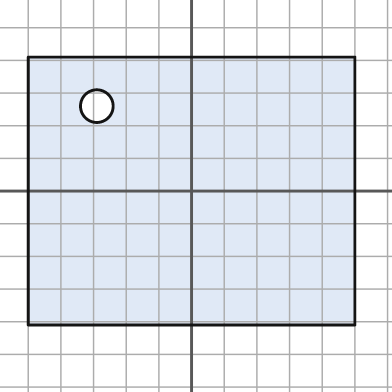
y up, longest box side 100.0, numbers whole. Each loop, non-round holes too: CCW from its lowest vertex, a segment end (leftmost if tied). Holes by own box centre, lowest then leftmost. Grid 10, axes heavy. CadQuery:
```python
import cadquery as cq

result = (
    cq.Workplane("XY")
    .moveTo(-50.0, -41.0)
    .lineTo(50.0, -41.0)
    .lineTo(50.0, 41.0)
    .lineTo(-50.0, 41.0)
    .close()
    .moveTo(-29.0, 26.0)
    .circle(5.0)
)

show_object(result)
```